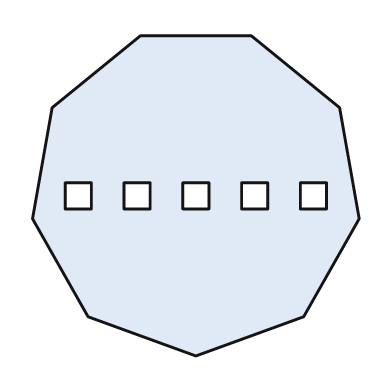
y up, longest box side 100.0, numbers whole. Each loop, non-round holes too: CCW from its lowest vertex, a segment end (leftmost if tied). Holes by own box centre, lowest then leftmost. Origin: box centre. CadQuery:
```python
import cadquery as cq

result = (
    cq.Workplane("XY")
    .moveTo(0.0, -49.0)
    .lineTo(33.0, -37.0)
    .lineTo(50.0, -7.0)
    .lineTo(44.0, 27.0)
    .lineTo(17.0, 49.0)
    .lineTo(-17.0, 49.0)
    .lineTo(-44.0, 27.0)
    .lineTo(-50.0, -7.0)
    .lineTo(-33.0, -37.0)
    .close()
    .moveTo(-40.0, -4.0)
    .lineTo(-32.0, -4.0)
    .lineTo(-32.0, 4.0)
    .lineTo(-40.0, 4.0)
    .close()
    .moveTo(-22.0, -4.0)
    .lineTo(-14.0, -4.0)
    .lineTo(-14.0, 4.0)
    .lineTo(-22.0, 4.0)
    .close()
    .moveTo(-4.0, -4.0)
    .lineTo(4.0, -4.0)
    .lineTo(4.0, 4.0)
    .lineTo(-4.0, 4.0)
    .close()
    .moveTo(14.0, -4.0)
    .lineTo(22.0, -4.0)
    .lineTo(22.0, 4.0)
    .lineTo(14.0, 4.0)
    .close()
    .moveTo(32.0, -4.0)
    .lineTo(40.0, -4.0)
    .lineTo(40.0, 4.0)
    .lineTo(32.0, 4.0)
    .close()
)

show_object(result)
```